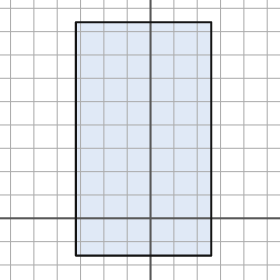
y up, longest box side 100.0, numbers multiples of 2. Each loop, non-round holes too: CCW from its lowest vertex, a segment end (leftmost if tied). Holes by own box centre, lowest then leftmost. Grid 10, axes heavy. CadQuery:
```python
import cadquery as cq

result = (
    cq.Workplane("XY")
    .moveTo(-32.0, -16.0)
    .lineTo(26.0, -16.0)
    .lineTo(26.0, 84.0)
    .lineTo(-32.0, 84.0)
    .close()
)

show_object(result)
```